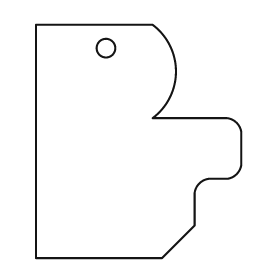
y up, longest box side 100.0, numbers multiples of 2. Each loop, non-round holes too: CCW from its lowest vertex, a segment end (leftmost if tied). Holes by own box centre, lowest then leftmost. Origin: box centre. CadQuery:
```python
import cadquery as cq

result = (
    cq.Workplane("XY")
    .moveTo(-44.0, -50.0)
    .lineTo(10.0, -50.0)
    .lineTo(24.0, -36.0)
    .lineTo(24.0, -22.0)
    .threePointArc((26.0, -18.0), (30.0, -16.0))
    .lineTo(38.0, -16.0)
    .threePointArc((42.0, -14.0), (44.0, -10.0))
    .lineTo(44.0, 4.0)
    .threePointArc((42.0, 8.0), (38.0, 10.0))
    .lineTo(6.0, 10.0)
    .threePointArc((16.0, 30.0), (6.0, 50.0))
    .lineTo(-44.0, 50.0)
    .close()
    .moveTo(-14.0, 40.0)
    .circle(4.0)
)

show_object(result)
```